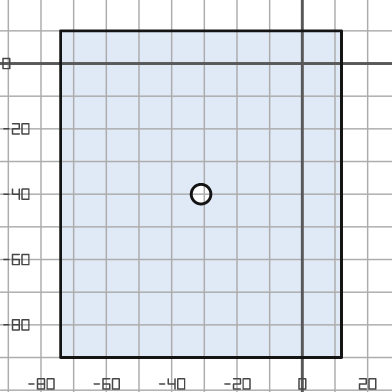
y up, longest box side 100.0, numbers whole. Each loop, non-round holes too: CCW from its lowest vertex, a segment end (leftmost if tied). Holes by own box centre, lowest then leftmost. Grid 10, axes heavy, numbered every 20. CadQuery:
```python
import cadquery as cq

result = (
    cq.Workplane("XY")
    .moveTo(-74.0, -90.0)
    .lineTo(12.0, -90.0)
    .lineTo(12.0, 10.0)
    .lineTo(-74.0, 10.0)
    .close()
    .moveTo(-31.0, -40.0)
    .circle(3.0)
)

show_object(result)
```